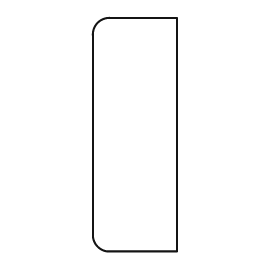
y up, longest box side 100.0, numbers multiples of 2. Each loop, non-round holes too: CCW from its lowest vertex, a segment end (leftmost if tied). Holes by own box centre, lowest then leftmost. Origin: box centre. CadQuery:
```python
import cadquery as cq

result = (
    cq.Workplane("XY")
    .moveTo(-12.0, -50.0)
    .lineTo(18.0, -50.0)
    .lineTo(18.0, 50.0)
    .lineTo(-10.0, 50.0)
    .threePointArc((-16.0, 48.0), (-18.0, 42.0))
    .lineTo(-18.0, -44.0)
    .threePointArc((-16.0, -48.0), (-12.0, -50.0))
    .close()
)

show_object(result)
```